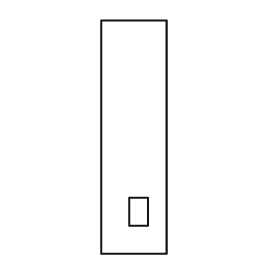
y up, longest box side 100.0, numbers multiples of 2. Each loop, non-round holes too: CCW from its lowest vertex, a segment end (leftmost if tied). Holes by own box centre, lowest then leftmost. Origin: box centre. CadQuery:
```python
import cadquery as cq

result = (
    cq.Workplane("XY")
    .moveTo(-14.0, -50.0)
    .lineTo(14.0, -50.0)
    .lineTo(14.0, 50.0)
    .lineTo(-14.0, 50.0)
    .close()
    .moveTo(-2.0, -38.0)
    .lineTo(6.0, -38.0)
    .lineTo(6.0, -26.0)
    .lineTo(-2.0, -26.0)
    .close()
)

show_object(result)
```